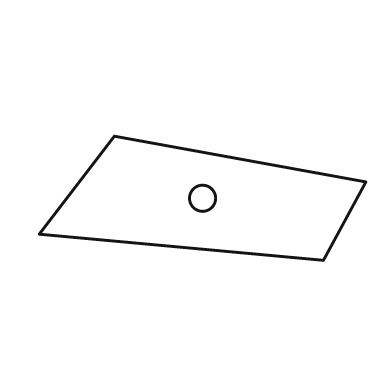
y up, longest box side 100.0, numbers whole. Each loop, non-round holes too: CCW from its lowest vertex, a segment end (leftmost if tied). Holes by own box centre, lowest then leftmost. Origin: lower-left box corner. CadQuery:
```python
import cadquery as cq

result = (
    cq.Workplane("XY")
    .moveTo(87.0, 0.0)
    .lineTo(100.0, 24.0)
    .lineTo(23.0, 38.0)
    .lineTo(0.0, 8.0)
    .close()
    .moveTo(50.0, 19.0)
    .circle(4.0)
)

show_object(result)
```